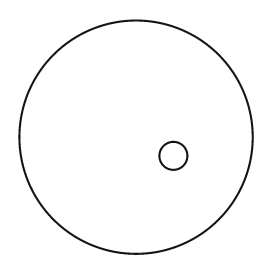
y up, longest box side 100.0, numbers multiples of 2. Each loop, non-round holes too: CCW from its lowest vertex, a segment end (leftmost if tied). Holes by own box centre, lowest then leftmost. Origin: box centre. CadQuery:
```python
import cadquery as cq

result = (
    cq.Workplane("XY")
    .moveTo(0.0, 0.0)
    .circle(50.0)
    .moveTo(16.0, -8.0)
    .circle(6.0)
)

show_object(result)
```